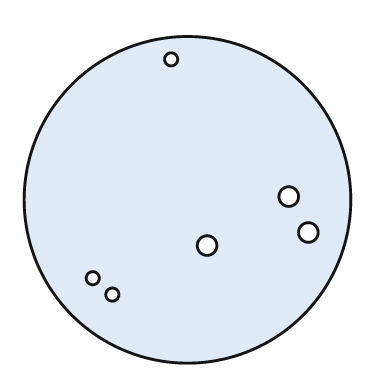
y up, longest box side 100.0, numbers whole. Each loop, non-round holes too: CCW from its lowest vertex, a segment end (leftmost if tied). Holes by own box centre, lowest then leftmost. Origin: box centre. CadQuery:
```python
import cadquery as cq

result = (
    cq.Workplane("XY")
    .moveTo(0.0, 0.0)
    .circle(50.0)
    .moveTo(-23.0, -29.0)
    .circle(2.0)
    .moveTo(-29.0, -24.0)
    .circle(2.0)
    .moveTo(6.0, -14.0)
    .circle(3.0)
    .moveTo(37.0, -10.0)
    .circle(3.0)
    .moveTo(31.0, 1.0)
    .circle(3.0)
    .moveTo(-5.0, 43.0)
    .circle(2.0)
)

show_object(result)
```